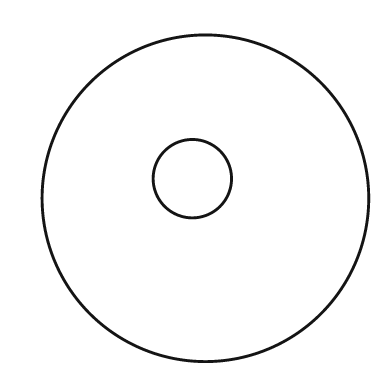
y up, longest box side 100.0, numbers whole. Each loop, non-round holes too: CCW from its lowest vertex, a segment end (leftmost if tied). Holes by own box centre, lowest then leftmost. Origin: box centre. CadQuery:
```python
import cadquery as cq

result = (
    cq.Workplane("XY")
    .moveTo(0.0, 0.0)
    .circle(50.0)
    .moveTo(-4.0, 6.0)
    .circle(12.0)
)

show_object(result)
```